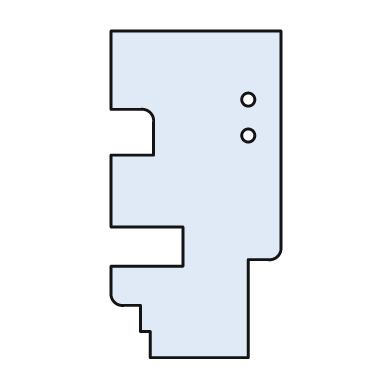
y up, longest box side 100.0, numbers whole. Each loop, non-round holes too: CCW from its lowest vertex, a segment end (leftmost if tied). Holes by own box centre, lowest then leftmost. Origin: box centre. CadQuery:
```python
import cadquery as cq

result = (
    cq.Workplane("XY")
    .moveTo(-14.0, -50.0)
    .lineTo(16.0, -50.0)
    .lineTo(16.0, -20.0)
    .lineTo(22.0, -20.0)
    .threePointArc((25.0, -19.0), (26.0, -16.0))
    .lineTo(26.0, 50.0)
    .lineTo(-26.0, 50.0)
    .lineTo(-26.0, 26.0)
    .lineTo(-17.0, 26.0)
    .threePointArc((-14.0, 25.0), (-13.0, 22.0))
    .lineTo(-13.0, 12.0)
    .lineTo(-26.0, 12.0)
    .lineTo(-26.0, -10.0)
    .lineTo(-4.0, -10.0)
    .lineTo(-4.0, -22.0)
    .lineTo(-26.0, -22.0)
    .lineTo(-26.0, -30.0)
    .threePointArc((-25.0, -33.0), (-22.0, -34.0))
    .lineTo(-17.0, -34.0)
    .lineTo(-17.0, -42.0)
    .lineTo(-14.0, -42.0)
    .close()
    .moveTo(16.0, 18.0)
    .circle(2.0)
    .moveTo(16.0, 29.0)
    .circle(2.0)
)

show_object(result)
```